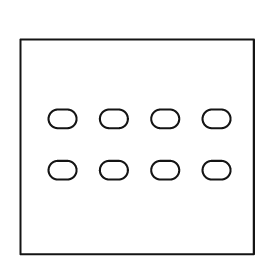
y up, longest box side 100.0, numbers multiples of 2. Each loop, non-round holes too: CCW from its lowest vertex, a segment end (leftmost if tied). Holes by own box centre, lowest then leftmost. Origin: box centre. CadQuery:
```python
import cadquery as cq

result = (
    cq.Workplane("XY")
    .moveTo(-50.0, -46.0)
    .lineTo(50.0, -46.0)
    .lineTo(50.0, 46.0)
    .lineTo(-50.0, 46.0)
    .close()
    .moveTo(-34.0, -14.0)
    .lineTo(-30.0, -14.0)
    .threePointArc((-26.0, -10.0), (-30.0, -6.0))
    .lineTo(-34.0, -6.0)
    .threePointArc((-38.0, -10.0), (-34.0, -14.0))
    .close()
    .moveTo(-12.0, -14.0)
    .lineTo(-8.0, -14.0)
    .threePointArc((-4.0, -10.0), (-8.0, -6.0))
    .lineTo(-12.0, -6.0)
    .threePointArc((-16.0, -10.0), (-12.0, -14.0))
    .close()
    .moveTo(10.0, -14.0)
    .lineTo(14.0, -14.0)
    .threePointArc((18.0, -10.0), (14.0, -6.0))
    .lineTo(10.0, -6.0)
    .threePointArc((6.0, -10.0), (10.0, -14.0))
    .close()
    .moveTo(32.0, -14.0)
    .lineTo(36.0, -14.0)
    .threePointArc((40.0, -10.0), (36.0, -6.0))
    .lineTo(32.0, -6.0)
    .threePointArc((28.0, -10.0), (32.0, -14.0))
    .close()
    .moveTo(-34.0, 8.0)
    .lineTo(-30.0, 8.0)
    .threePointArc((-26.0, 12.0), (-30.0, 16.0))
    .lineTo(-34.0, 16.0)
    .threePointArc((-38.0, 12.0), (-34.0, 8.0))
    .close()
    .moveTo(-12.0, 8.0)
    .lineTo(-8.0, 8.0)
    .threePointArc((-4.0, 12.0), (-8.0, 16.0))
    .lineTo(-12.0, 16.0)
    .threePointArc((-16.0, 12.0), (-12.0, 8.0))
    .close()
    .moveTo(10.0, 8.0)
    .lineTo(14.0, 8.0)
    .threePointArc((18.0, 12.0), (14.0, 16.0))
    .lineTo(10.0, 16.0)
    .threePointArc((6.0, 12.0), (10.0, 8.0))
    .close()
    .moveTo(32.0, 8.0)
    .lineTo(36.0, 8.0)
    .threePointArc((40.0, 12.0), (36.0, 16.0))
    .lineTo(32.0, 16.0)
    .threePointArc((28.0, 12.0), (32.0, 8.0))
    .close()
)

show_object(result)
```